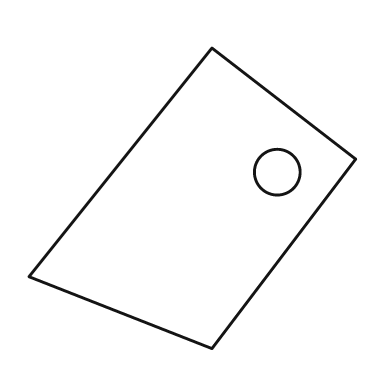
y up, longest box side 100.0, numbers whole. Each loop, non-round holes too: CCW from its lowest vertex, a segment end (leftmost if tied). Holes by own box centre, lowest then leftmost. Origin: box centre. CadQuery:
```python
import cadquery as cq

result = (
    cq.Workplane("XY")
    .moveTo(6.0, -46.0)
    .lineTo(50.0, 12.0)
    .lineTo(6.0, 46.0)
    .lineTo(-50.0, -24.0)
    .close()
    .moveTo(26.0, 8.0)
    .circle(7.0)
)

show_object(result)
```